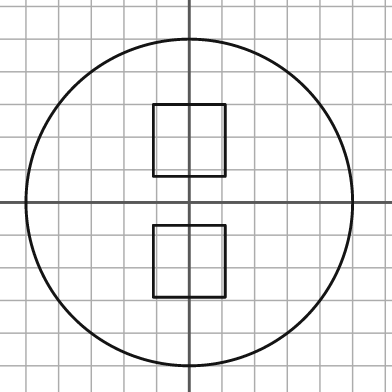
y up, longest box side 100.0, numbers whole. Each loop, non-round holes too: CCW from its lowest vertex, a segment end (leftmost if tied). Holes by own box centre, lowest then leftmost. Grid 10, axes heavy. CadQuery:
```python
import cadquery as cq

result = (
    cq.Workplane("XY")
    .moveTo(0.0, 0.0)
    .circle(50.0)
    .moveTo(-11.0, -29.0)
    .lineTo(11.0, -29.0)
    .lineTo(11.0, -7.0)
    .lineTo(-11.0, -7.0)
    .close()
    .moveTo(-11.0, 8.0)
    .lineTo(11.0, 8.0)
    .lineTo(11.0, 30.0)
    .lineTo(-11.0, 30.0)
    .close()
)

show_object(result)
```